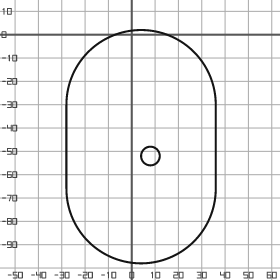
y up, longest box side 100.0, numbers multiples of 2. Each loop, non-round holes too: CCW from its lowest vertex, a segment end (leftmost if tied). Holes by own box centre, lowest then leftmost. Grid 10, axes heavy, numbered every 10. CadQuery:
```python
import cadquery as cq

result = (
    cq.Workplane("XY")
    .moveTo(-28.0, -66.0)
    .threePointArc((4.0, -98.0), (36.0, -66.0))
    .lineTo(36.0, -30.0)
    .threePointArc((4.0, 2.0), (-28.0, -30.0))
    .close()
    .moveTo(8.0, -52.0)
    .circle(4.0)
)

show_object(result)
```